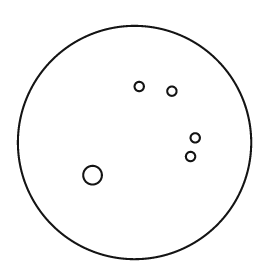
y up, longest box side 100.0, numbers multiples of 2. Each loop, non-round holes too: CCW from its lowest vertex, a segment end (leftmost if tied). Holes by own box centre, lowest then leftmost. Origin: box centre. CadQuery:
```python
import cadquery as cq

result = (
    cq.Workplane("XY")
    .moveTo(0.0, 0.0)
    .circle(50.0)
    .moveTo(-18.0, -14.0)
    .circle(4.0)
    .moveTo(24.0, -6.0)
    .circle(2.0)
    .moveTo(26.0, 2.0)
    .circle(2.0)
    .moveTo(16.0, 22.0)
    .circle(2.0)
    .moveTo(2.0, 24.0)
    .circle(2.0)
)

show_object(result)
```